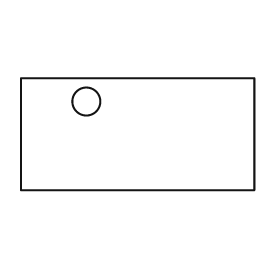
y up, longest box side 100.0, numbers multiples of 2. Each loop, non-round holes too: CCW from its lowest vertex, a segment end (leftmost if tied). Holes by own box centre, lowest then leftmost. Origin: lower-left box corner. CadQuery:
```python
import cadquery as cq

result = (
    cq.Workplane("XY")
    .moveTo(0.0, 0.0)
    .lineTo(100.0, 0.0)
    .lineTo(100.0, 48.0)
    .lineTo(0.0, 48.0)
    .close()
    .moveTo(28.0, 38.0)
    .circle(6.0)
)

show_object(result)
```